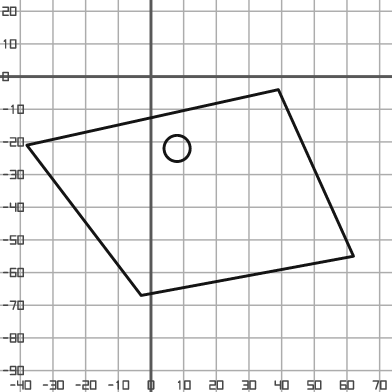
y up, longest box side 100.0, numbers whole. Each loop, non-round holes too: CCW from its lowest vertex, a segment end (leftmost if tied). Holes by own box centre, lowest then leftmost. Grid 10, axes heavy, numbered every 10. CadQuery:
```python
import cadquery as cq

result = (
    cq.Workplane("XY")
    .moveTo(-3.0, -67.0)
    .lineTo(62.0, -55.0)
    .lineTo(39.0, -4.0)
    .lineTo(-38.0, -21.0)
    .close()
    .moveTo(8.0, -22.0)
    .circle(4.0)
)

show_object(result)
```